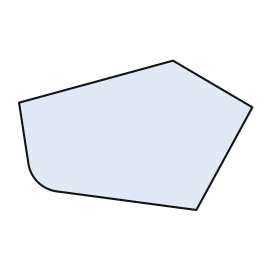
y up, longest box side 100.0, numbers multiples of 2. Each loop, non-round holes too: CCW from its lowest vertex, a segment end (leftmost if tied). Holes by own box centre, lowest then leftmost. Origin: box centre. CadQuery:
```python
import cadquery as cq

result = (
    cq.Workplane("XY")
    .moveTo(26.0, -32.0)
    .lineTo(50.0, 12.0)
    .lineTo(16.0, 32.0)
    .lineTo(-50.0, 14.0)
    .lineTo(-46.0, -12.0)
    .threePointArc((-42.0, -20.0), (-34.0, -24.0))
    .close()
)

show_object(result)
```